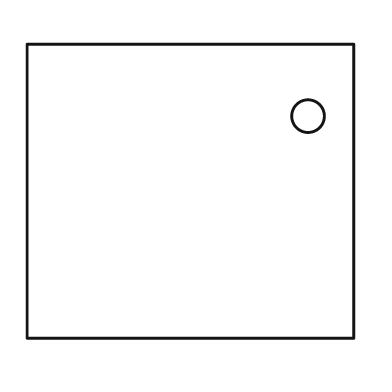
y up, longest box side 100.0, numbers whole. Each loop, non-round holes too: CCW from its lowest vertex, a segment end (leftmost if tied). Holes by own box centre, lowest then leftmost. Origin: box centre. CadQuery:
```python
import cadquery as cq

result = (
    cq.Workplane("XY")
    .moveTo(-50.0, -45.0)
    .lineTo(50.0, -45.0)
    .lineTo(50.0, 45.0)
    .lineTo(-50.0, 45.0)
    .close()
    .moveTo(36.0, 23.0)
    .circle(5.0)
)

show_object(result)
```